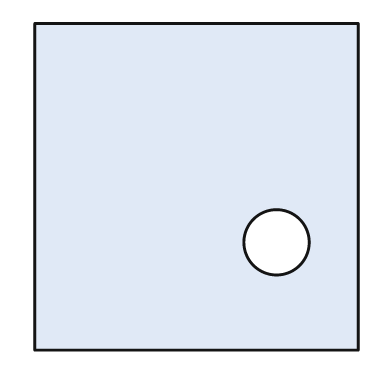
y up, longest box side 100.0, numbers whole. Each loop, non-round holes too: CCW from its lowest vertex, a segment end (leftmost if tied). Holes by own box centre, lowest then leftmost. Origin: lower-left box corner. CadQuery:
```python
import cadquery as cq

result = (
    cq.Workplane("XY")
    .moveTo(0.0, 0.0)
    .lineTo(99.0, 0.0)
    .lineTo(99.0, 100.0)
    .lineTo(0.0, 100.0)
    .close()
    .moveTo(74.0, 33.0)
    .circle(10.0)
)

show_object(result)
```